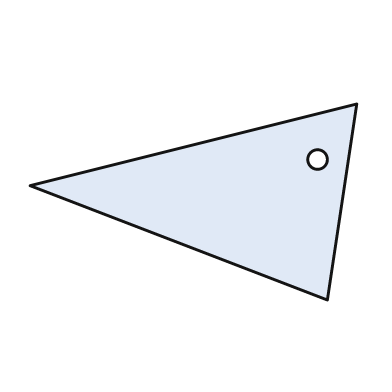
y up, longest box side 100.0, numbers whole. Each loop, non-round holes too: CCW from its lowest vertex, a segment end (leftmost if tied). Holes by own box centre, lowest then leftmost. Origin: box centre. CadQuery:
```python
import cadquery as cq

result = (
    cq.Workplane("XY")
    .moveTo(41.0, -30.0)
    .lineTo(50.0, 30.0)
    .lineTo(-50.0, 5.0)
    .close()
    .moveTo(38.0, 13.0)
    .circle(3.0)
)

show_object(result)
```